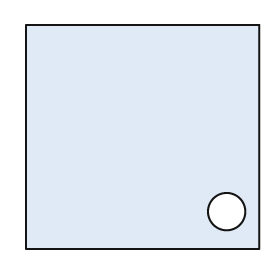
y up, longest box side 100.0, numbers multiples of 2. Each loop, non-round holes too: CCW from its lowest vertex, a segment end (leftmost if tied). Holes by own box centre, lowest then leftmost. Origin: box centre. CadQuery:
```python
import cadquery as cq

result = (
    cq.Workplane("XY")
    .moveTo(-50.0, -48.0)
    .lineTo(50.0, -48.0)
    .lineTo(50.0, 48.0)
    .lineTo(-50.0, 48.0)
    .close()
    .moveTo(36.0, -32.0)
    .circle(8.0)
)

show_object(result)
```